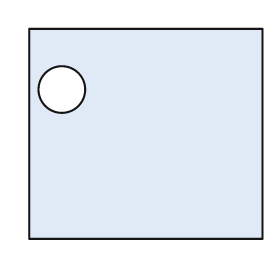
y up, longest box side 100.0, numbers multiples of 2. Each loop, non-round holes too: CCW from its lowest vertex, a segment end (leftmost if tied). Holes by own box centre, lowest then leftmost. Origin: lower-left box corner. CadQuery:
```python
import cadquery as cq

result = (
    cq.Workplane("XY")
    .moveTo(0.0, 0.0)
    .lineTo(100.0, 0.0)
    .lineTo(100.0, 90.0)
    .lineTo(0.0, 90.0)
    .close()
    .moveTo(14.0, 64.0)
    .circle(10.0)
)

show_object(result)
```